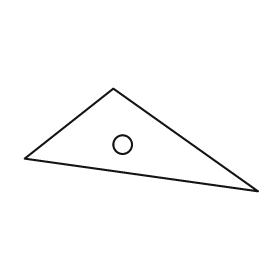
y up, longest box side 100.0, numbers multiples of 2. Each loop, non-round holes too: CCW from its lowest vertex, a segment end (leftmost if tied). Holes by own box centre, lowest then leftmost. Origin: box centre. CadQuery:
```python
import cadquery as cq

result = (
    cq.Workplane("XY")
    .moveTo(50.0, -22.0)
    .lineTo(-12.0, 22.0)
    .lineTo(-50.0, -8.0)
    .close()
    .moveTo(-8.0, -2.0)
    .circle(4.0)
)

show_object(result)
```